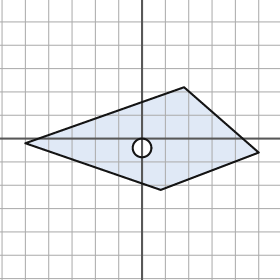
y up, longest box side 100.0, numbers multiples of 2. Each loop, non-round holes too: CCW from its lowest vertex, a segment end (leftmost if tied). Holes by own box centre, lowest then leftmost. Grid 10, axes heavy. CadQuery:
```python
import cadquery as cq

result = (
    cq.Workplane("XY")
    .moveTo(8.0, -22.0)
    .lineTo(50.0, -6.0)
    .lineTo(18.0, 22.0)
    .lineTo(-50.0, -2.0)
    .close()
    .moveTo(0.0, -4.0)
    .circle(4.0)
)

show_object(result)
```